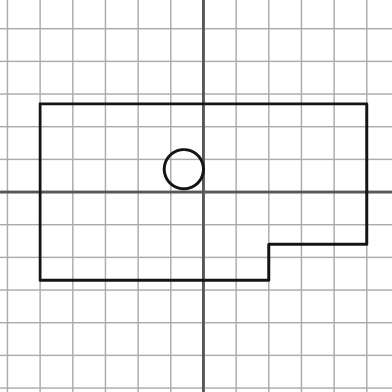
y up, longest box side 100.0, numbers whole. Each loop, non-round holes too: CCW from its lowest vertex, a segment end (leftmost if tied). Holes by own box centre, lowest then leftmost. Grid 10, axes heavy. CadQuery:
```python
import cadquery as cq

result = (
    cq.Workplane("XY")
    .moveTo(-50.0, -27.0)
    .lineTo(20.0, -27.0)
    .lineTo(20.0, -16.0)
    .lineTo(50.0, -16.0)
    .lineTo(50.0, 27.0)
    .lineTo(-50.0, 27.0)
    .close()
    .moveTo(-6.0, 7.0)
    .circle(6.0)
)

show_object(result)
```